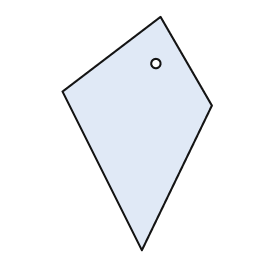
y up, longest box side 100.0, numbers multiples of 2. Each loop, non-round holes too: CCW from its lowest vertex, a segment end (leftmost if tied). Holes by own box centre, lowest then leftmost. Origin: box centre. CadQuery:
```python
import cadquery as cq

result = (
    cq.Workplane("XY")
    .moveTo(2.0, -50.0)
    .lineTo(32.0, 12.0)
    .lineTo(10.0, 50.0)
    .lineTo(-32.0, 18.0)
    .close()
    .moveTo(8.0, 30.0)
    .circle(2.0)
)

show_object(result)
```